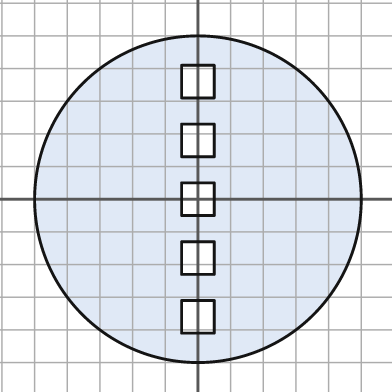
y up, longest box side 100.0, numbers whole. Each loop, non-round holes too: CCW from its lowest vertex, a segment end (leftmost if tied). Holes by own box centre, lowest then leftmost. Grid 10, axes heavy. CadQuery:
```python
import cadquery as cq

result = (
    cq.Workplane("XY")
    .moveTo(0.0, 0.0)
    .circle(50.0)
    .moveTo(-5.0, -41.0)
    .lineTo(5.0, -41.0)
    .lineTo(5.0, -31.0)
    .lineTo(-5.0, -31.0)
    .close()
    .moveTo(-5.0, -23.0)
    .lineTo(5.0, -23.0)
    .lineTo(5.0, -13.0)
    .lineTo(-5.0, -13.0)
    .close()
    .moveTo(-5.0, -5.0)
    .lineTo(5.0, -5.0)
    .lineTo(5.0, 5.0)
    .lineTo(-5.0, 5.0)
    .close()
    .moveTo(-5.0, 13.0)
    .lineTo(5.0, 13.0)
    .lineTo(5.0, 23.0)
    .lineTo(-5.0, 23.0)
    .close()
    .moveTo(-5.0, 31.0)
    .lineTo(5.0, 31.0)
    .lineTo(5.0, 41.0)
    .lineTo(-5.0, 41.0)
    .close()
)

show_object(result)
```